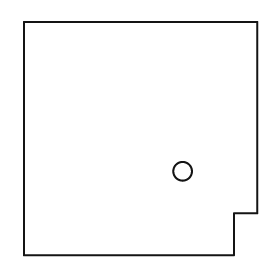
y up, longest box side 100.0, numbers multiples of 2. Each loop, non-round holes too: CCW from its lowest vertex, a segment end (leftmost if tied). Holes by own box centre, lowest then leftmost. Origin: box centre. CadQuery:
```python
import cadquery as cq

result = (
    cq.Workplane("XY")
    .moveTo(-50.0, -50.0)
    .lineTo(40.0, -50.0)
    .lineTo(40.0, -32.0)
    .lineTo(50.0, -32.0)
    .lineTo(50.0, 50.0)
    .lineTo(-50.0, 50.0)
    .close()
    .moveTo(18.0, -14.0)
    .circle(4.0)
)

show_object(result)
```